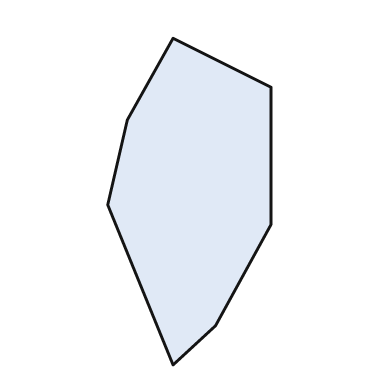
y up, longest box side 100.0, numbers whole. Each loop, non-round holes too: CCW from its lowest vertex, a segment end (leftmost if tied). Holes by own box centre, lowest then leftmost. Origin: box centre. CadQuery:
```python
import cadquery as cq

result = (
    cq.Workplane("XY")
    .moveTo(-5.0, -50.0)
    .lineTo(8.0, -38.0)
    .lineTo(25.0, -7.0)
    .lineTo(25.0, 35.0)
    .lineTo(-5.0, 50.0)
    .lineTo(-19.0, 25.0)
    .lineTo(-25.0, -1.0)
    .close()
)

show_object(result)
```